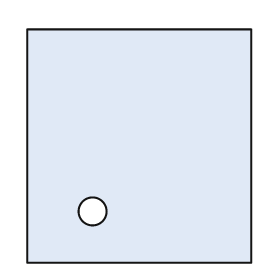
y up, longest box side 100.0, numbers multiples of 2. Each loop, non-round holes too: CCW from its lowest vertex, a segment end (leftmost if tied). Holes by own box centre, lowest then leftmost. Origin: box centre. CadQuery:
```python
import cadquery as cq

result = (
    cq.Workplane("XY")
    .moveTo(-48.0, -50.0)
    .lineTo(48.0, -50.0)
    .lineTo(48.0, 50.0)
    .lineTo(-48.0, 50.0)
    .close()
    .moveTo(-20.0, -28.0)
    .circle(6.0)
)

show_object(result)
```